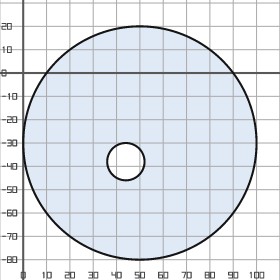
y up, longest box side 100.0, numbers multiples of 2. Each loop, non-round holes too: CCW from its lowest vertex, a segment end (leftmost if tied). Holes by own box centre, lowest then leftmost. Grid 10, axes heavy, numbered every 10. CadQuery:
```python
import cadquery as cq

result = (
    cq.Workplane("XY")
    .moveTo(50.0, -30.0)
    .circle(50.0)
    .moveTo(44.0, -38.0)
    .circle(8.0)
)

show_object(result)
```